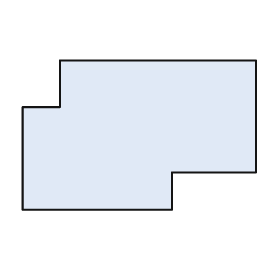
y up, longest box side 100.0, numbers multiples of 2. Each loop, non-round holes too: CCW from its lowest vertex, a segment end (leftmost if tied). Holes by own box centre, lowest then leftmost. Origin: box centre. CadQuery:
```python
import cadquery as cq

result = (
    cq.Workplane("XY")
    .moveTo(-50.0, -32.0)
    .lineTo(14.0, -32.0)
    .lineTo(14.0, -16.0)
    .lineTo(50.0, -16.0)
    .lineTo(50.0, 32.0)
    .lineTo(-34.0, 32.0)
    .lineTo(-34.0, 12.0)
    .lineTo(-50.0, 12.0)
    .close()
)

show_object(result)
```